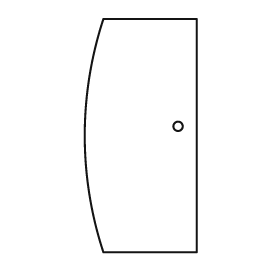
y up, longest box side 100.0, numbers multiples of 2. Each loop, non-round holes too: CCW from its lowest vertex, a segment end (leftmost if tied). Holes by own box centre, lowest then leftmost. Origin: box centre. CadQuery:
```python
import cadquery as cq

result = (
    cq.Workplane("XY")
    .moveTo(-16.0, -50.0)
    .lineTo(24.0, -50.0)
    .lineTo(24.0, 50.0)
    .lineTo(-16.0, 50.0)
    .threePointArc((-24.0, 0.0), (-16.0, -50.0))
    .close()
    .moveTo(16.0, 4.0)
    .circle(2.0)
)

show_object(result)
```